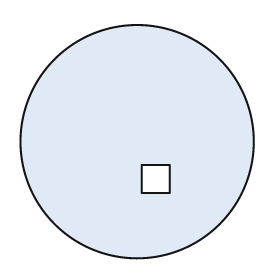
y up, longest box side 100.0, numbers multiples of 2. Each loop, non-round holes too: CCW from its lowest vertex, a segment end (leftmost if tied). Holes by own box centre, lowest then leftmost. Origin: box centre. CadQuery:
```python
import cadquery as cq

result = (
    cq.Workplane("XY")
    .moveTo(0.0, 0.0)
    .circle(50.0)
    .moveTo(2.0, -22.0)
    .lineTo(14.0, -22.0)
    .lineTo(14.0, -10.0)
    .lineTo(2.0, -10.0)
    .close()
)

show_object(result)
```